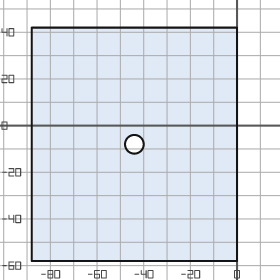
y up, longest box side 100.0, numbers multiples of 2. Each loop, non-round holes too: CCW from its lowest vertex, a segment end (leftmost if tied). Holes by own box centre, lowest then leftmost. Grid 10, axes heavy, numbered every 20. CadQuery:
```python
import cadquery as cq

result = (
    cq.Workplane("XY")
    .moveTo(-88.0, -58.0)
    .lineTo(0.0, -58.0)
    .lineTo(0.0, 42.0)
    .lineTo(-88.0, 42.0)
    .close()
    .moveTo(-44.0, -8.0)
    .circle(4.0)
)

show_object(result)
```